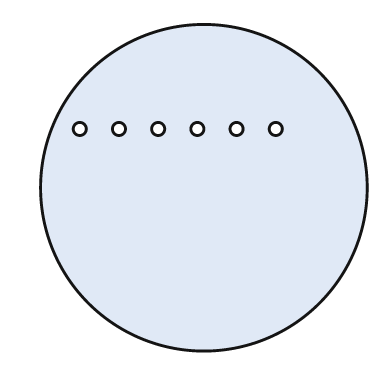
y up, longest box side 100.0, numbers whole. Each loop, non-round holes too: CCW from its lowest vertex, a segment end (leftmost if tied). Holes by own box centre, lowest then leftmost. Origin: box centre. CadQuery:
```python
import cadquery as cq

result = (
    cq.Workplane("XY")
    .moveTo(0.0, 0.0)
    .circle(50.0)
    .moveTo(-38.0, 18.0)
    .circle(2.0)
    .moveTo(-26.0, 18.0)
    .circle(2.0)
    .moveTo(-14.0, 18.0)
    .circle(2.0)
    .moveTo(-2.0, 18.0)
    .circle(2.0)
    .moveTo(10.0, 18.0)
    .circle(2.0)
    .moveTo(22.0, 18.0)
    .circle(2.0)
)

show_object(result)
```